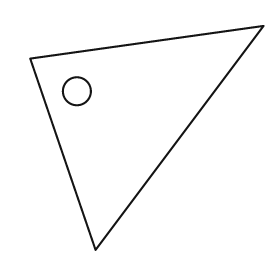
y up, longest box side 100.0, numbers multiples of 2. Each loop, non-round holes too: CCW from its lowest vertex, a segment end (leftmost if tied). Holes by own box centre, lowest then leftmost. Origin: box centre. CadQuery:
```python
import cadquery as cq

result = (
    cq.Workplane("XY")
    .moveTo(-22.0, -48.0)
    .lineTo(50.0, 48.0)
    .lineTo(-50.0, 34.0)
    .close()
    .moveTo(-30.0, 20.0)
    .circle(6.0)
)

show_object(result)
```